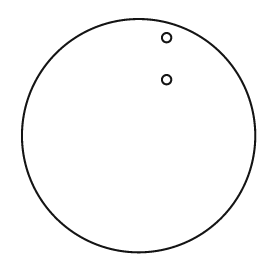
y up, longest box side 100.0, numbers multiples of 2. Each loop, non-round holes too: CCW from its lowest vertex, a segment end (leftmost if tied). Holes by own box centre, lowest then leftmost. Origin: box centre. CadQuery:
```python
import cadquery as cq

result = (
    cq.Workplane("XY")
    .moveTo(0.0, 0.0)
    .circle(50.0)
    .moveTo(12.0, 24.0)
    .circle(2.0)
    .moveTo(12.0, 42.0)
    .circle(2.0)
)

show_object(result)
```